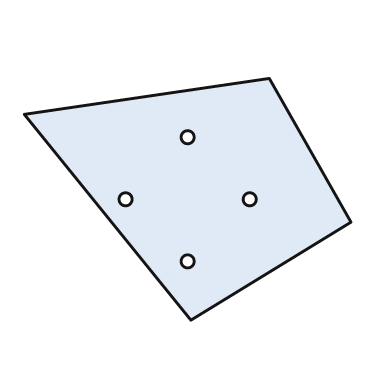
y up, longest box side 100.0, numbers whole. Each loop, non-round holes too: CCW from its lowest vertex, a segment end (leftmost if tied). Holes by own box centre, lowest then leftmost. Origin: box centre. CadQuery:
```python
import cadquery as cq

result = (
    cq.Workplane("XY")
    .moveTo(1.0, -37.0)
    .lineTo(50.0, -7.0)
    .lineTo(25.0, 37.0)
    .lineTo(-50.0, 26.0)
    .close()
    .moveTo(0.0, -19.0)
    .circle(2.0)
    .moveTo(-19.0, 0.0)
    .circle(2.0)
    .moveTo(19.0, 0.0)
    .circle(2.0)
    .moveTo(0.0, 19.0)
    .circle(2.0)
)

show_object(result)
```